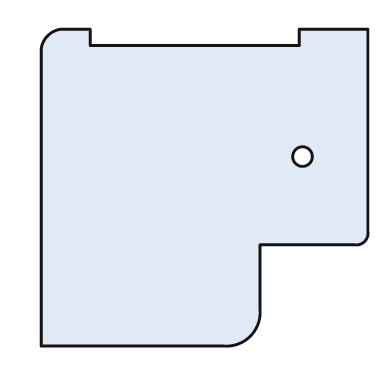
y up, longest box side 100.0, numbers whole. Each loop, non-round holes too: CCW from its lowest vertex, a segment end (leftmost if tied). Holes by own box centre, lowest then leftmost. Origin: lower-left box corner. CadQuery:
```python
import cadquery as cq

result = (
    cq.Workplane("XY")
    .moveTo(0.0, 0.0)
    .lineTo(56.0, 0.0)
    .threePointArc((64.0, 3.0), (67.0, 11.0))
    .lineTo(67.0, 31.0)
    .lineTo(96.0, 31.0)
    .threePointArc((99.0, 32.0), (100.0, 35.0))
    .lineTo(100.0, 97.0)
    .lineTo(79.0, 97.0)
    .lineTo(79.0, 92.0)
    .lineTo(15.0, 92.0)
    .lineTo(15.0, 97.0)
    .lineTo(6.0, 97.0)
    .threePointArc((2.0, 95.0), (0.0, 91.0))
    .close()
    .moveTo(80.0, 58.0)
    .circle(3.0)
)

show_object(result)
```